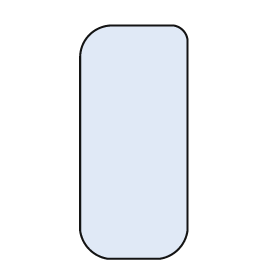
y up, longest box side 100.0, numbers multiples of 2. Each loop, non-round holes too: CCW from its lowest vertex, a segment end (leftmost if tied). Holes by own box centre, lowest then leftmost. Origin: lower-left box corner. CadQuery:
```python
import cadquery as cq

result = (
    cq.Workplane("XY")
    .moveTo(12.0, 0.0)
    .lineTo(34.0, 0.0)
    .threePointArc((42.0, 4.0), (46.0, 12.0))
    .lineTo(46.0, 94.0)
    .threePointArc((44.0, 98.0), (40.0, 100.0))
    .lineTo(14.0, 100.0)
    .threePointArc((4.0, 96.0), (0.0, 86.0))
    .lineTo(0.0, 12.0)
    .threePointArc((4.0, 4.0), (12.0, 0.0))
    .close()
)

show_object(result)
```